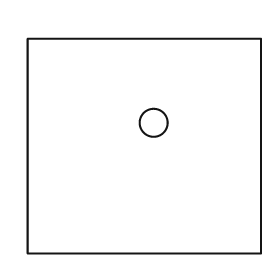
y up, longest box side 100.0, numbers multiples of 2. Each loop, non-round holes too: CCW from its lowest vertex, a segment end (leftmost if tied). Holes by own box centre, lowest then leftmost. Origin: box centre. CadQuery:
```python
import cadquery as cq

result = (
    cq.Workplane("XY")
    .moveTo(-50.0, -46.0)
    .lineTo(50.0, -46.0)
    .lineTo(50.0, 46.0)
    .lineTo(-50.0, 46.0)
    .close()
    .moveTo(4.0, 10.0)
    .circle(6.0)
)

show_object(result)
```